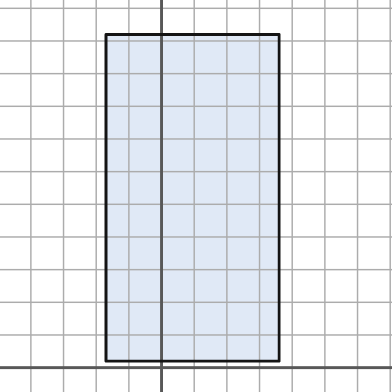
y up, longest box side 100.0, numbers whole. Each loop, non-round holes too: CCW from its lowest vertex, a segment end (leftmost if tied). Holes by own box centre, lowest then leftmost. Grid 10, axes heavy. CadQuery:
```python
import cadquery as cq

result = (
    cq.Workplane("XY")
    .moveTo(-17.0, 2.0)
    .lineTo(36.0, 2.0)
    .lineTo(36.0, 102.0)
    .lineTo(-17.0, 102.0)
    .close()
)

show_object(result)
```